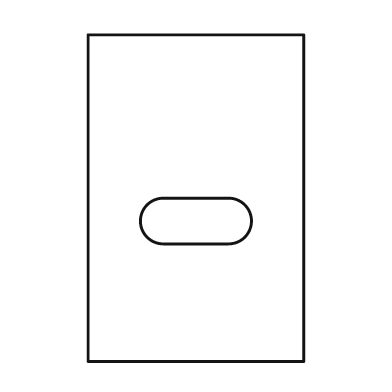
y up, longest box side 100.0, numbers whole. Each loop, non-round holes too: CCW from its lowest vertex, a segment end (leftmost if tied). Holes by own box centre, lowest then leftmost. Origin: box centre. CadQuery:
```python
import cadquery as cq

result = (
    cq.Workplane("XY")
    .moveTo(-33.0, -50.0)
    .lineTo(33.0, -50.0)
    .lineTo(33.0, 50.0)
    .lineTo(-33.0, 50.0)
    .close()
    .moveTo(-10.0, -14.0)
    .lineTo(10.0, -14.0)
    .threePointArc((17.0, -7.0), (10.0, 0.0))
    .lineTo(-10.0, 0.0)
    .threePointArc((-17.0, -7.0), (-10.0, -14.0))
    .close()
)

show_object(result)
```